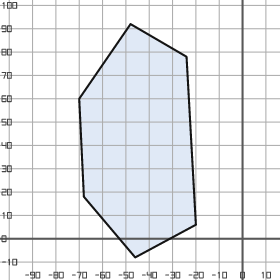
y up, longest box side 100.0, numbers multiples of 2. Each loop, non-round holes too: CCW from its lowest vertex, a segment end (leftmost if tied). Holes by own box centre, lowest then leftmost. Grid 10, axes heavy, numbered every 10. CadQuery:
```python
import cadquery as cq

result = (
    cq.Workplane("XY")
    .moveTo(-46.0, -8.0)
    .lineTo(-20.0, 6.0)
    .lineTo(-24.0, 78.0)
    .lineTo(-48.0, 92.0)
    .lineTo(-70.0, 60.0)
    .lineTo(-68.0, 18.0)
    .close()
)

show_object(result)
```